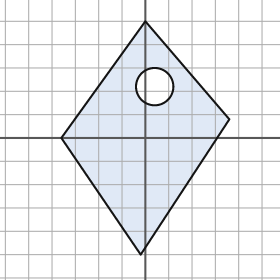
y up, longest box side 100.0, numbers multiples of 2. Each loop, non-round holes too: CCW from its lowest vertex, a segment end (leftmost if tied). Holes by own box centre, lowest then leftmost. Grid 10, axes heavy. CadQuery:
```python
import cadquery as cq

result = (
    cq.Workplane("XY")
    .moveTo(-2.0, -50.0)
    .lineTo(36.0, 8.0)
    .lineTo(0.0, 50.0)
    .lineTo(-36.0, 0.0)
    .close()
    .moveTo(4.0, 22.0)
    .circle(8.0)
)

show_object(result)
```